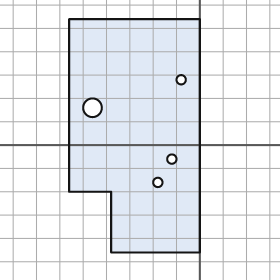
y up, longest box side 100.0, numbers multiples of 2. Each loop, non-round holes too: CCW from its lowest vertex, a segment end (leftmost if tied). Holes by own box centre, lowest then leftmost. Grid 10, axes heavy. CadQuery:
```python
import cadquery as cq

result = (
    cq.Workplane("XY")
    .moveTo(-38.0, -46.0)
    .lineTo(0.0, -46.0)
    .lineTo(0.0, 54.0)
    .lineTo(-56.0, 54.0)
    .lineTo(-56.0, -20.0)
    .lineTo(-38.0, -20.0)
    .close()
    .moveTo(-18.0, -16.0)
    .circle(2.0)
    .moveTo(-12.0, -6.0)
    .circle(2.0)
    .moveTo(-46.0, 16.0)
    .circle(4.0)
    .moveTo(-8.0, 28.0)
    .circle(2.0)
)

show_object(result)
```